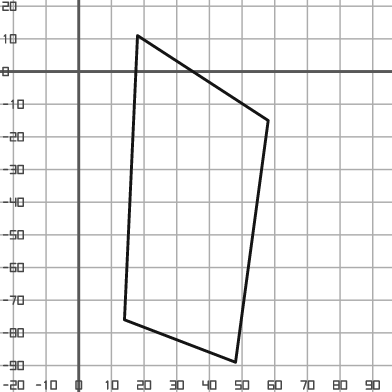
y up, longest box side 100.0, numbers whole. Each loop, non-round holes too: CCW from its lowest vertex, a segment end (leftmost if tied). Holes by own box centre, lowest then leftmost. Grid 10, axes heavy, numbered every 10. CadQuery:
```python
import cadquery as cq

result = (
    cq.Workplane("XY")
    .moveTo(48.0, -89.0)
    .lineTo(58.0, -15.0)
    .lineTo(18.0, 11.0)
    .lineTo(14.0, -76.0)
    .close()
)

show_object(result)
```